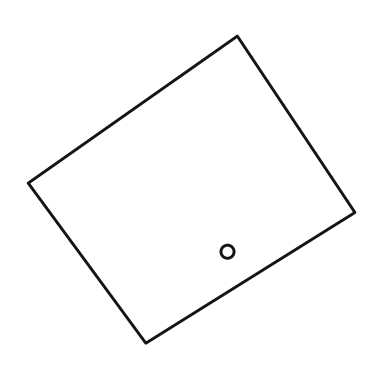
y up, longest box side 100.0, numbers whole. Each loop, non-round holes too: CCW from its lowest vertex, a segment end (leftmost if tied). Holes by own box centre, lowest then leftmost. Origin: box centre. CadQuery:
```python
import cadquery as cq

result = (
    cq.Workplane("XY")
    .moveTo(-14.0, -47.0)
    .lineTo(50.0, -7.0)
    .lineTo(14.0, 47.0)
    .lineTo(-50.0, 2.0)
    .close()
    .moveTo(11.0, -19.0)
    .circle(2.0)
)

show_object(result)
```